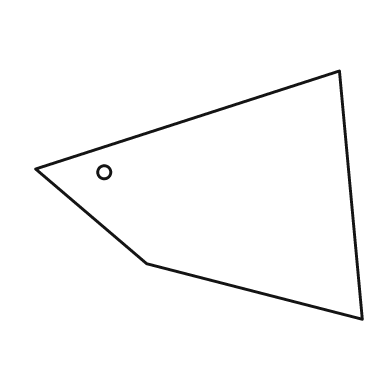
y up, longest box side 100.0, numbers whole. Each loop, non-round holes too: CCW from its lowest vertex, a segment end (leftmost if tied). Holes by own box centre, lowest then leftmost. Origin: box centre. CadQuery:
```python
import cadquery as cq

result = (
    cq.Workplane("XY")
    .moveTo(50.0, -38.0)
    .lineTo(43.0, 38.0)
    .lineTo(-50.0, 8.0)
    .lineTo(-16.0, -21.0)
    .close()
    .moveTo(-29.0, 7.0)
    .circle(2.0)
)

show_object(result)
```